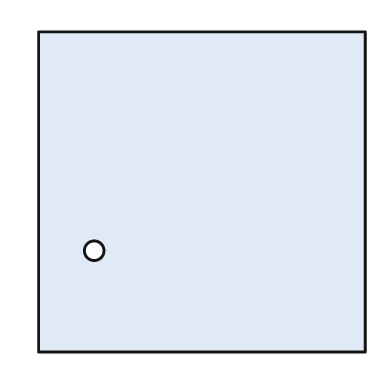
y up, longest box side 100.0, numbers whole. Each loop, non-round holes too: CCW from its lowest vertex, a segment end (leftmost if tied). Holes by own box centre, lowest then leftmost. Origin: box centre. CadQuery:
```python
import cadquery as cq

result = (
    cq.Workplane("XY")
    .moveTo(-50.0, -49.0)
    .lineTo(50.0, -49.0)
    .lineTo(50.0, 49.0)
    .lineTo(-50.0, 49.0)
    .close()
    .moveTo(-33.0, -18.0)
    .circle(3.0)
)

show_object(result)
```